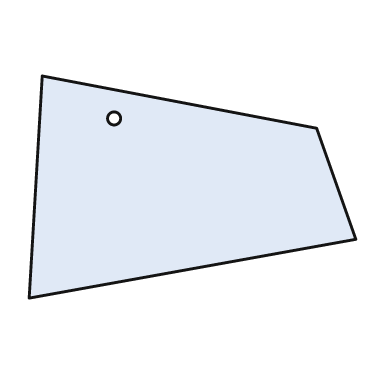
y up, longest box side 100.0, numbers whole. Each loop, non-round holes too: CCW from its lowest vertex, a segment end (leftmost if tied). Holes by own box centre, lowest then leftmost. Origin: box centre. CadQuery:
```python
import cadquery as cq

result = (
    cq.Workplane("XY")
    .moveTo(-50.0, -34.0)
    .lineTo(50.0, -16.0)
    .lineTo(38.0, 18.0)
    .lineTo(-46.0, 34.0)
    .close()
    .moveTo(-24.0, 21.0)
    .circle(2.0)
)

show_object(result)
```